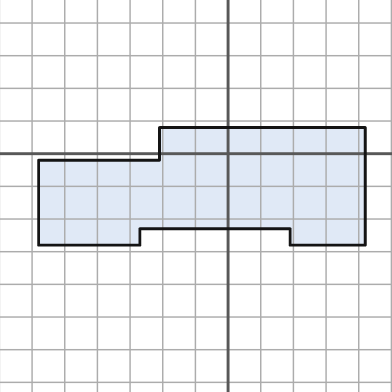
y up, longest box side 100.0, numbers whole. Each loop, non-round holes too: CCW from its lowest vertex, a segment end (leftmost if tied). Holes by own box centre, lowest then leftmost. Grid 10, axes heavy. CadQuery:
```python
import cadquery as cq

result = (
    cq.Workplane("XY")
    .moveTo(-58.0, -28.0)
    .lineTo(-27.0, -28.0)
    .lineTo(-27.0, -23.0)
    .lineTo(19.0, -23.0)
    .lineTo(19.0, -28.0)
    .lineTo(42.0, -28.0)
    .lineTo(42.0, 8.0)
    .lineTo(-21.0, 8.0)
    .lineTo(-21.0, -2.0)
    .lineTo(-58.0, -2.0)
    .close()
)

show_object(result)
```